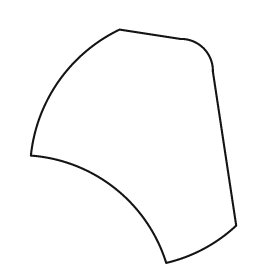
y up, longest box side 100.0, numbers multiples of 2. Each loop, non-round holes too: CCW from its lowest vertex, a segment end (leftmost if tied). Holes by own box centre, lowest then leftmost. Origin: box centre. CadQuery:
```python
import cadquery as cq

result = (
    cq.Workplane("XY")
    .moveTo(14.0, -50.0)
    .threePointArc((30.0, -44.0), (44.0, -34.0))
    .lineTo(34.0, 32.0)
    .threePointArc((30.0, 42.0), (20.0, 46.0))
    .lineTo(-6.0, 50.0)
    .threePointArc((-32.0, 28.0), (-44.0, -4.0))
    .threePointArc((-8.0, -18.0), (14.0, -50.0))
    .close()
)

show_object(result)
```